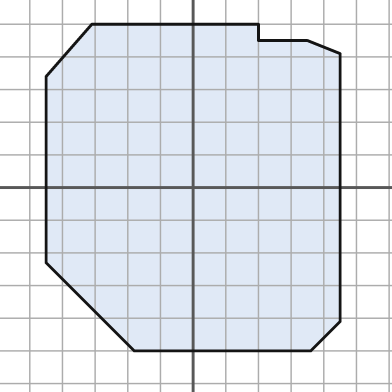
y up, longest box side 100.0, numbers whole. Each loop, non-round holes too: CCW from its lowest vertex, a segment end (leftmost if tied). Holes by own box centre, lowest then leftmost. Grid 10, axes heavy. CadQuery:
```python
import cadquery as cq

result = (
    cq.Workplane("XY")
    .moveTo(-18.0, -50.0)
    .lineTo(36.0, -50.0)
    .lineTo(45.0, -41.0)
    .lineTo(45.0, 41.0)
    .lineTo(35.0, 45.0)
    .lineTo(20.0, 45.0)
    .lineTo(20.0, 50.0)
    .lineTo(-31.0, 50.0)
    .lineTo(-45.0, 34.0)
    .lineTo(-45.0, -23.0)
    .close()
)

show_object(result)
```